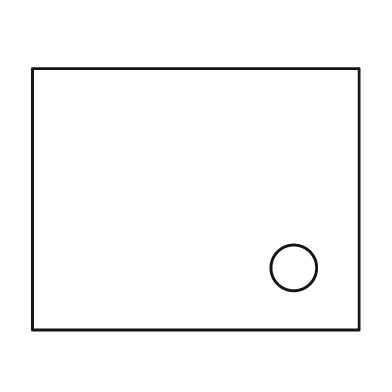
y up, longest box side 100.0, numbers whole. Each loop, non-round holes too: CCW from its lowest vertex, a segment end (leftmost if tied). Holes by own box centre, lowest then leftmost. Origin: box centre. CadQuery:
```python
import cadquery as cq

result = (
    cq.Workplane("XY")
    .moveTo(-50.0, -40.0)
    .lineTo(50.0, -40.0)
    .lineTo(50.0, 40.0)
    .lineTo(-50.0, 40.0)
    .close()
    .moveTo(30.0, -21.0)
    .circle(7.0)
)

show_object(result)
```